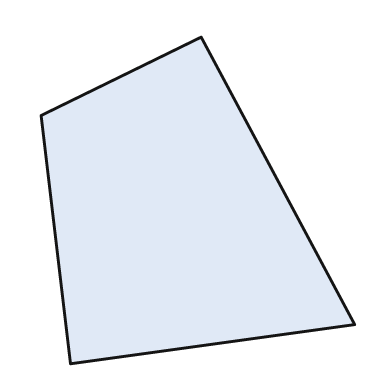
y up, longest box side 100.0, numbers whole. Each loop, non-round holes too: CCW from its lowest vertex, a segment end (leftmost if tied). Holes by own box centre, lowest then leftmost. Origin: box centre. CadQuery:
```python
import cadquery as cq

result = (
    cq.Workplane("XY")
    .moveTo(-39.0, -50.0)
    .lineTo(48.0, -38.0)
    .lineTo(1.0, 50.0)
    .lineTo(-48.0, 26.0)
    .close()
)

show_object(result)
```